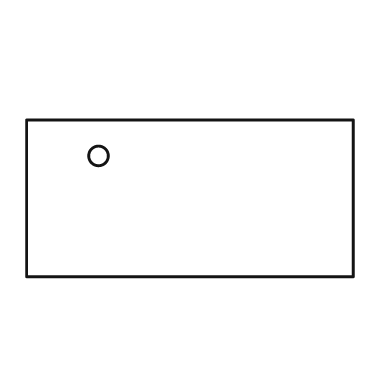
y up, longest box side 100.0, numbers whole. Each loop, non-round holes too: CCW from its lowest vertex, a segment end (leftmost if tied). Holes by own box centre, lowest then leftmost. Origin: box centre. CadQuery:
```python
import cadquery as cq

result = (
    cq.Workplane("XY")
    .moveTo(-50.0, -24.0)
    .lineTo(50.0, -24.0)
    .lineTo(50.0, 24.0)
    .lineTo(-50.0, 24.0)
    .close()
    .moveTo(-28.0, 13.0)
    .circle(3.0)
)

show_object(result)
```